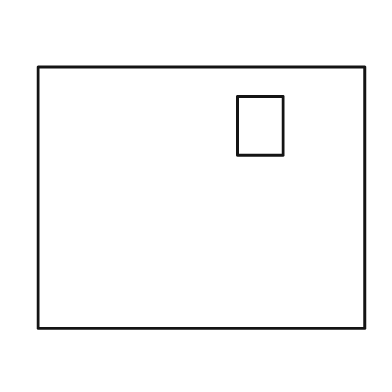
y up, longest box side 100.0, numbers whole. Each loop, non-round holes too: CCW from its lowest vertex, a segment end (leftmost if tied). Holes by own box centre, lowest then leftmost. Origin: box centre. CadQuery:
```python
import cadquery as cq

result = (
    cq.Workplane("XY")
    .moveTo(-50.0, -40.0)
    .lineTo(50.0, -40.0)
    .lineTo(50.0, 40.0)
    .lineTo(-50.0, 40.0)
    .close()
    .moveTo(11.0, 13.0)
    .lineTo(25.0, 13.0)
    .lineTo(25.0, 31.0)
    .lineTo(11.0, 31.0)
    .close()
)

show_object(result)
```